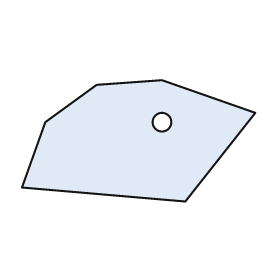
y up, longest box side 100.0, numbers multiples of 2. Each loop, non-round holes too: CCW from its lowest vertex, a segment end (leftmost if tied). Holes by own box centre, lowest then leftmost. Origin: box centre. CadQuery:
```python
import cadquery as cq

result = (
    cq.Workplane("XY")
    .moveTo(20.0, -26.0)
    .lineTo(50.0, 12.0)
    .lineTo(10.0, 26.0)
    .lineTo(-18.0, 24.0)
    .lineTo(-40.0, 8.0)
    .lineTo(-50.0, -20.0)
    .close()
    .moveTo(10.0, 8.0)
    .circle(4.0)
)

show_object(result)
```